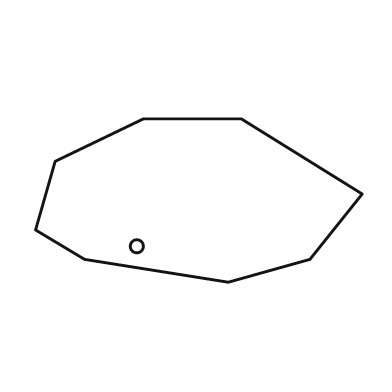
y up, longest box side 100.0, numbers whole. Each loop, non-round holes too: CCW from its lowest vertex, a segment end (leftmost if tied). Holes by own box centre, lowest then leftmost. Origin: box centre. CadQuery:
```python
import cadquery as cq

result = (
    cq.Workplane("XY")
    .moveTo(9.0, -25.0)
    .lineTo(34.0, -18.0)
    .lineTo(50.0, 2.0)
    .lineTo(13.0, 25.0)
    .lineTo(-17.0, 25.0)
    .lineTo(-44.0, 12.0)
    .lineTo(-50.0, -9.0)
    .lineTo(-35.0, -18.0)
    .close()
    .moveTo(-19.0, -14.0)
    .circle(2.0)
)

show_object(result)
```